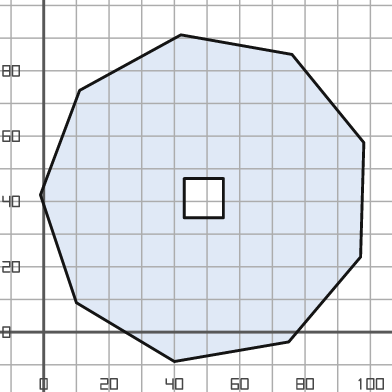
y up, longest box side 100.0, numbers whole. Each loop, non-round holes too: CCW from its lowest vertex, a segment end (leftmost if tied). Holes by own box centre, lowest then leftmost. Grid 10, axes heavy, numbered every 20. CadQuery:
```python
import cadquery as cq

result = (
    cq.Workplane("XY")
    .moveTo(40.0, -9.0)
    .lineTo(75.0, -3.0)
    .lineTo(97.0, 23.0)
    .lineTo(98.0, 58.0)
    .lineTo(76.0, 85.0)
    .lineTo(42.0, 91.0)
    .lineTo(11.0, 74.0)
    .lineTo(-1.0, 42.0)
    .lineTo(10.0, 9.0)
    .close()
    .moveTo(43.0, 35.0)
    .lineTo(55.0, 35.0)
    .lineTo(55.0, 47.0)
    .lineTo(43.0, 47.0)
    .close()
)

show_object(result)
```